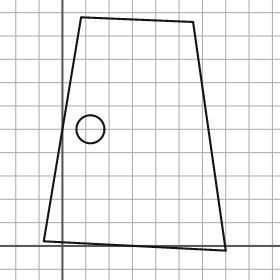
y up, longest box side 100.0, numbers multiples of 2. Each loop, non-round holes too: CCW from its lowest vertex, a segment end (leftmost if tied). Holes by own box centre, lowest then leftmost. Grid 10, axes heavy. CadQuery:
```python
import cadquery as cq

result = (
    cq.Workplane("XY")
    .moveTo(70.0, -2.0)
    .lineTo(56.0, 96.0)
    .lineTo(8.0, 98.0)
    .lineTo(-8.0, 2.0)
    .close()
    .moveTo(12.0, 50.0)
    .circle(6.0)
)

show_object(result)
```